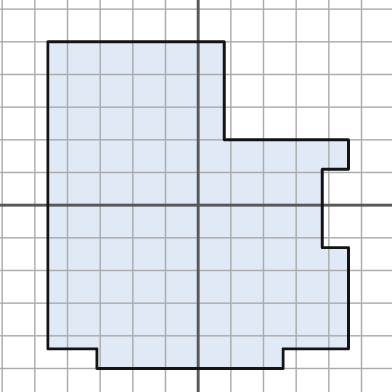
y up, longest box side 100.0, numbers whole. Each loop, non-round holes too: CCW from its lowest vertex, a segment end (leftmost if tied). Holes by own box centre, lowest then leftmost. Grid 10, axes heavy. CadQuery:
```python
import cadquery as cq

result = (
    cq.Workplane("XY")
    .moveTo(-31.0, -50.0)
    .lineTo(26.0, -50.0)
    .lineTo(26.0, -44.0)
    .lineTo(46.0, -44.0)
    .lineTo(46.0, -13.0)
    .lineTo(38.0, -13.0)
    .lineTo(38.0, 11.0)
    .lineTo(46.0, 11.0)
    .lineTo(46.0, 20.0)
    .lineTo(8.0, 20.0)
    .lineTo(8.0, 50.0)
    .lineTo(-46.0, 50.0)
    .lineTo(-46.0, -44.0)
    .lineTo(-31.0, -44.0)
    .close()
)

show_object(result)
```